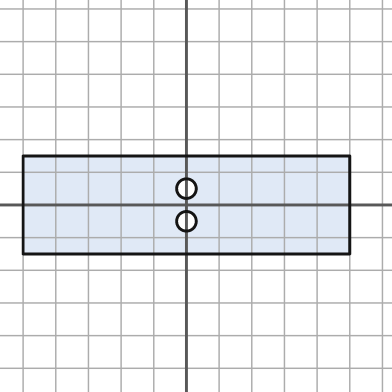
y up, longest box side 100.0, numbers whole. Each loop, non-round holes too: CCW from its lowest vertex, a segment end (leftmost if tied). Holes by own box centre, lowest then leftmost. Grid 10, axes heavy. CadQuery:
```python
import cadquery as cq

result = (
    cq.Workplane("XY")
    .moveTo(-50.0, -15.0)
    .lineTo(50.0, -15.0)
    .lineTo(50.0, 15.0)
    .lineTo(-50.0, 15.0)
    .close()
    .moveTo(0.0, -5.0)
    .circle(3.0)
    .moveTo(0.0, 5.0)
    .circle(3.0)
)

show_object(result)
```